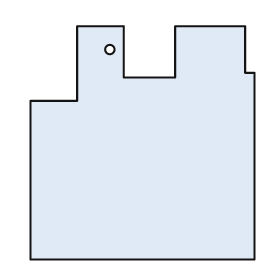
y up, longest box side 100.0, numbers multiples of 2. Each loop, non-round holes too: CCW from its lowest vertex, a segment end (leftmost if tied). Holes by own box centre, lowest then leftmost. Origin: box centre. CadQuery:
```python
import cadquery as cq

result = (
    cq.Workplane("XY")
    .moveTo(-48.0, -50.0)
    .lineTo(48.0, -50.0)
    .lineTo(48.0, 30.0)
    .lineTo(44.0, 30.0)
    .lineTo(44.0, 50.0)
    .lineTo(14.0, 50.0)
    .lineTo(14.0, 28.0)
    .lineTo(-8.0, 28.0)
    .lineTo(-8.0, 50.0)
    .lineTo(-28.0, 50.0)
    .lineTo(-28.0, 18.0)
    .lineTo(-48.0, 18.0)
    .close()
    .moveTo(-14.0, 40.0)
    .circle(2.0)
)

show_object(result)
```